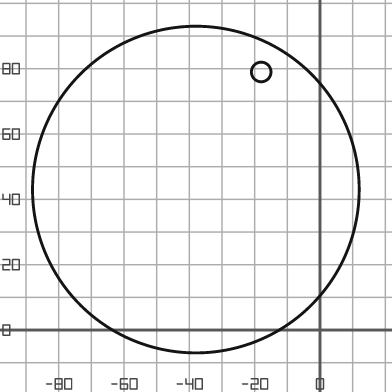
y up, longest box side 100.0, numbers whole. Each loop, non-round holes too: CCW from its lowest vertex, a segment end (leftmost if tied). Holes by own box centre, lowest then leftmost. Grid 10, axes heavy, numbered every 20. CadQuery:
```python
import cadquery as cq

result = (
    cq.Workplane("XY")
    .moveTo(-38.0, 43.0)
    .circle(50.0)
    .moveTo(-18.0, 79.0)
    .circle(3.0)
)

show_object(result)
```